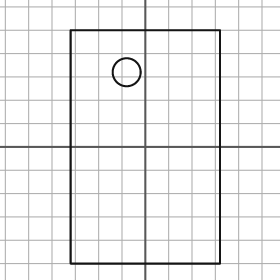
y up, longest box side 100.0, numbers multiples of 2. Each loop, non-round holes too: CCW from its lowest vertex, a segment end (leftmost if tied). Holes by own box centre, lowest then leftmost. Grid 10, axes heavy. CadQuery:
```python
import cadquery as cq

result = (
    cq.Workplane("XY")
    .moveTo(-32.0, -50.0)
    .lineTo(32.0, -50.0)
    .lineTo(32.0, 50.0)
    .lineTo(-32.0, 50.0)
    .close()
    .moveTo(-8.0, 32.0)
    .circle(6.0)
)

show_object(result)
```